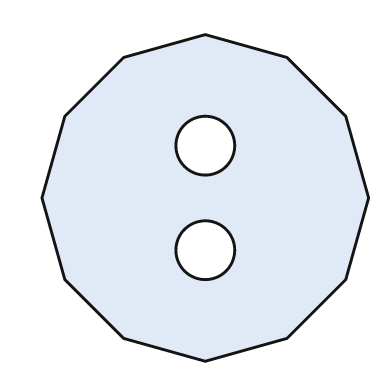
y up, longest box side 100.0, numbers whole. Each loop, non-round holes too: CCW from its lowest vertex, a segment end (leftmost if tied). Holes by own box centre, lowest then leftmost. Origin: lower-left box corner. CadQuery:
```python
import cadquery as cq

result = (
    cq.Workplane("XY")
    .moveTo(50.0, 0.0)
    .lineTo(75.0, 7.0)
    .lineTo(93.0, 25.0)
    .lineTo(100.0, 50.0)
    .lineTo(93.0, 75.0)
    .lineTo(75.0, 93.0)
    .lineTo(50.0, 100.0)
    .lineTo(25.0, 93.0)
    .lineTo(7.0, 75.0)
    .lineTo(0.0, 50.0)
    .lineTo(7.0, 25.0)
    .lineTo(25.0, 7.0)
    .close()
    .moveTo(50.0, 34.0)
    .circle(9.0)
    .moveTo(50.0, 66.0)
    .circle(9.0)
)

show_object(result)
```